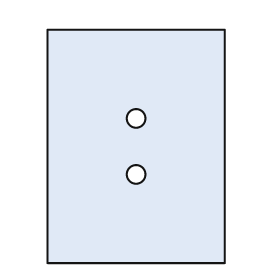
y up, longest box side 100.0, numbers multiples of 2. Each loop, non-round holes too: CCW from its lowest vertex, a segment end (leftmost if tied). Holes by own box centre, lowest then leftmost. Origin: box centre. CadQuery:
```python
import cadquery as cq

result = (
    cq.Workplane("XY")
    .moveTo(-38.0, -50.0)
    .lineTo(38.0, -50.0)
    .lineTo(38.0, 50.0)
    .lineTo(-38.0, 50.0)
    .close()
    .moveTo(0.0, -12.0)
    .circle(4.0)
    .moveTo(0.0, 12.0)
    .circle(4.0)
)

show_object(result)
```